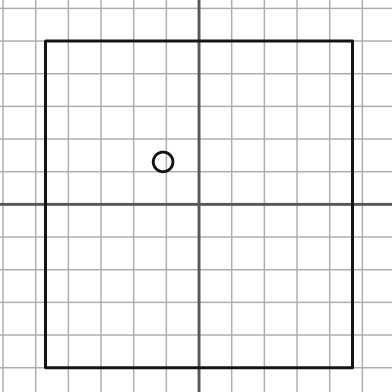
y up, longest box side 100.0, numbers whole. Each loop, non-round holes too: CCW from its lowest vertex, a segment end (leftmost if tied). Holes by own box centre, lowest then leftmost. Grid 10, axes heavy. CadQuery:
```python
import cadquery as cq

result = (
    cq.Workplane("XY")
    .moveTo(-47.0, -50.0)
    .lineTo(47.0, -50.0)
    .lineTo(47.0, 50.0)
    .lineTo(-47.0, 50.0)
    .close()
    .moveTo(-11.0, 13.0)
    .circle(3.0)
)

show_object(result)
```